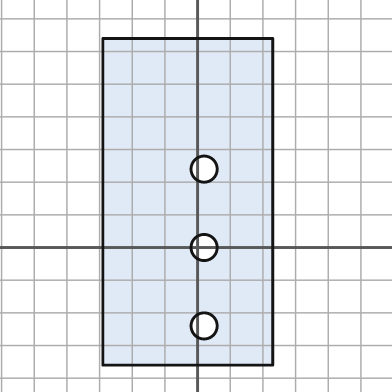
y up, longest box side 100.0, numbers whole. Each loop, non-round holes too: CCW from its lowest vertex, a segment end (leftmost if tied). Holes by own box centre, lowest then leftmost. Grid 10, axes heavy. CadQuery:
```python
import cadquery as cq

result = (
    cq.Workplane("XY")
    .moveTo(-29.0, -36.0)
    .lineTo(23.0, -36.0)
    .lineTo(23.0, 64.0)
    .lineTo(-29.0, 64.0)
    .close()
    .moveTo(2.0, -24.0)
    .circle(4.0)
    .moveTo(2.0, 0.0)
    .circle(4.0)
    .moveTo(2.0, 24.0)
    .circle(4.0)
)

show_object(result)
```